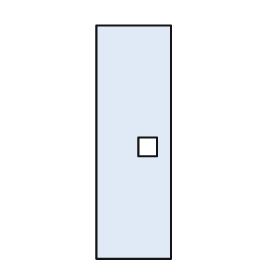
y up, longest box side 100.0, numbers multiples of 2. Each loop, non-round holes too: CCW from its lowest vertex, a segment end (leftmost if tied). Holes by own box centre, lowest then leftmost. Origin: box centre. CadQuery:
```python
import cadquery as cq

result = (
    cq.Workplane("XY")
    .moveTo(-16.0, -50.0)
    .lineTo(16.0, -50.0)
    .lineTo(16.0, 50.0)
    .lineTo(-16.0, 50.0)
    .close()
    .moveTo(2.0, -6.0)
    .lineTo(10.0, -6.0)
    .lineTo(10.0, 2.0)
    .lineTo(2.0, 2.0)
    .close()
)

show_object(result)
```